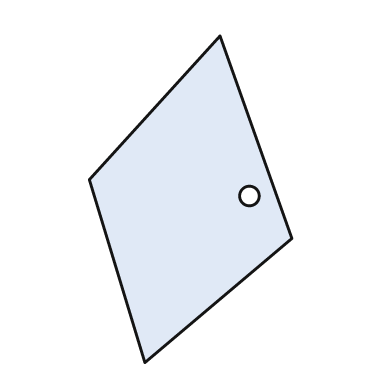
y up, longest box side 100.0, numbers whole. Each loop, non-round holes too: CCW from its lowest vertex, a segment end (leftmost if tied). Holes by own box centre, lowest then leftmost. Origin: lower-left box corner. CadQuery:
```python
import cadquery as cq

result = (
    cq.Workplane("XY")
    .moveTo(17.0, 0.0)
    .lineTo(62.0, 38.0)
    .lineTo(40.0, 100.0)
    .lineTo(0.0, 56.0)
    .close()
    .moveTo(49.0, 51.0)
    .circle(3.0)
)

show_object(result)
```